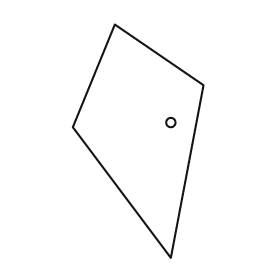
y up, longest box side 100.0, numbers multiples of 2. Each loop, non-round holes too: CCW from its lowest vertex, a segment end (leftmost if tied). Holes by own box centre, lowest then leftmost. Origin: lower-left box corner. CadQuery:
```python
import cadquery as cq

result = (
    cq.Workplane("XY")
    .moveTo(42.0, 0.0)
    .lineTo(56.0, 74.0)
    .lineTo(18.0, 100.0)
    .lineTo(0.0, 56.0)
    .close()
    .moveTo(42.0, 58.0)
    .circle(2.0)
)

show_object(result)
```